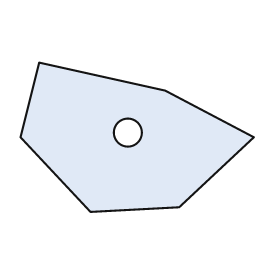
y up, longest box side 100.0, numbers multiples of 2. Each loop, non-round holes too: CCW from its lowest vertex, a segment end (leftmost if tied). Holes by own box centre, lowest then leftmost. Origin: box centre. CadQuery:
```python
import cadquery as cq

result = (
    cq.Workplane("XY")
    .moveTo(-20.0, -32.0)
    .lineTo(18.0, -30.0)
    .lineTo(50.0, 0.0)
    .lineTo(12.0, 20.0)
    .lineTo(-42.0, 32.0)
    .lineTo(-50.0, 0.0)
    .close()
    .moveTo(-4.0, 2.0)
    .circle(6.0)
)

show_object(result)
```